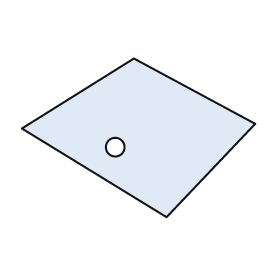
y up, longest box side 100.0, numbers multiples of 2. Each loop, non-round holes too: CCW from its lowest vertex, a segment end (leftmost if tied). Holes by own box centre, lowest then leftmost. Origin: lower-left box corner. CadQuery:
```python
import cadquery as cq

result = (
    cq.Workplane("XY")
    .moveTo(62.0, 0.0)
    .lineTo(100.0, 40.0)
    .lineTo(48.0, 68.0)
    .lineTo(0.0, 38.0)
    .close()
    .moveTo(40.0, 30.0)
    .circle(4.0)
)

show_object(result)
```